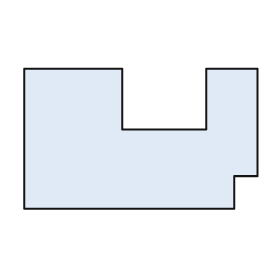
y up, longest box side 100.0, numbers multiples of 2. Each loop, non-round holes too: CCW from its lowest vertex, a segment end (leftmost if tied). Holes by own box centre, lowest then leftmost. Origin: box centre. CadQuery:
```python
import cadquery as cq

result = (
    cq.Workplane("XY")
    .moveTo(-50.0, -30.0)
    .lineTo(40.0, -30.0)
    .lineTo(40.0, -16.0)
    .lineTo(50.0, -16.0)
    .lineTo(50.0, 30.0)
    .lineTo(28.0, 30.0)
    .lineTo(28.0, 4.0)
    .lineTo(-8.0, 4.0)
    .lineTo(-8.0, 30.0)
    .lineTo(-50.0, 30.0)
    .close()
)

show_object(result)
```